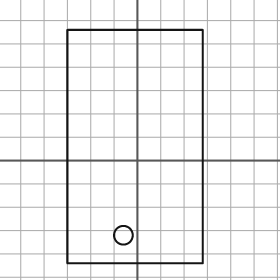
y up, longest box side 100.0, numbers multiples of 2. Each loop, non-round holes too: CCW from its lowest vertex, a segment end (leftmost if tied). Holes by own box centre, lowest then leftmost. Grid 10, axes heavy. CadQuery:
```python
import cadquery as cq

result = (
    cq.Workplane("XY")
    .moveTo(-30.0, -44.0)
    .lineTo(28.0, -44.0)
    .lineTo(28.0, 56.0)
    .lineTo(-30.0, 56.0)
    .close()
    .moveTo(-6.0, -32.0)
    .circle(4.0)
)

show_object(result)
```